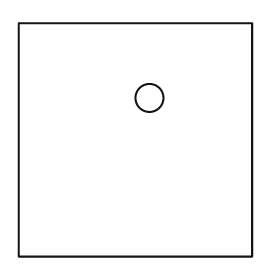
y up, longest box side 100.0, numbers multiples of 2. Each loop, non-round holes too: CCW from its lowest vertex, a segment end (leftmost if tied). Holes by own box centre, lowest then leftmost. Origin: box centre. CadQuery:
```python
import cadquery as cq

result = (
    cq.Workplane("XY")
    .moveTo(-50.0, -50.0)
    .lineTo(50.0, -50.0)
    .lineTo(50.0, 50.0)
    .lineTo(-50.0, 50.0)
    .close()
    .moveTo(6.0, 18.0)
    .circle(6.0)
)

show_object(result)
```